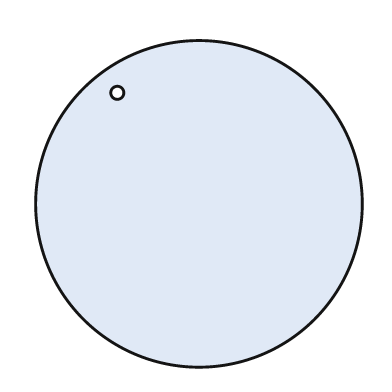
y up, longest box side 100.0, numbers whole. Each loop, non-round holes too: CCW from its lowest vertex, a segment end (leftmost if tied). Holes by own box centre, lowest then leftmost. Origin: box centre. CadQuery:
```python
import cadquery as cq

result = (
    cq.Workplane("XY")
    .moveTo(0.0, 0.0)
    .circle(50.0)
    .moveTo(-25.0, 34.0)
    .circle(2.0)
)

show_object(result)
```